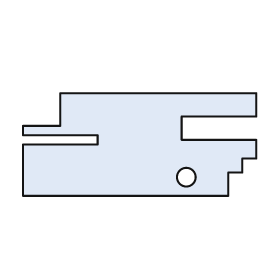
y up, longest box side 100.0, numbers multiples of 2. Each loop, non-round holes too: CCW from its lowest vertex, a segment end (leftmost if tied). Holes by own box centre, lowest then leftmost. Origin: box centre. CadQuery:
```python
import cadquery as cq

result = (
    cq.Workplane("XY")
    .moveTo(-50.0, -22.0)
    .lineTo(38.0, -22.0)
    .lineTo(38.0, -12.0)
    .lineTo(44.0, -12.0)
    .lineTo(44.0, -6.0)
    .lineTo(50.0, -6.0)
    .lineTo(50.0, 2.0)
    .lineTo(18.0, 2.0)
    .lineTo(18.0, 12.0)
    .lineTo(50.0, 12.0)
    .lineTo(50.0, 22.0)
    .lineTo(-34.0, 22.0)
    .lineTo(-34.0, 8.0)
    .lineTo(-50.0, 8.0)
    .lineTo(-50.0, 4.0)
    .lineTo(-18.0, 4.0)
    .lineTo(-18.0, 0.0)
    .lineTo(-50.0, 0.0)
    .close()
    .moveTo(20.0, -14.0)
    .circle(4.0)
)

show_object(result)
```